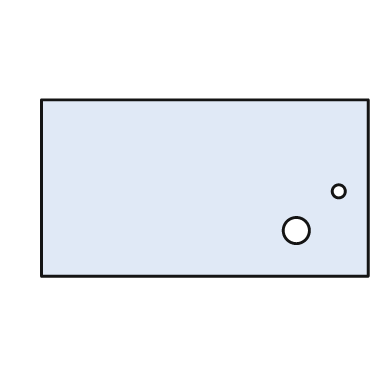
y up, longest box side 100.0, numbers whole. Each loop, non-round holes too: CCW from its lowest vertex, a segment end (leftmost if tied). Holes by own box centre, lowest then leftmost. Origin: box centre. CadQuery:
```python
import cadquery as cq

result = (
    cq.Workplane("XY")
    .moveTo(-50.0, -27.0)
    .lineTo(50.0, -27.0)
    .lineTo(50.0, 27.0)
    .lineTo(-50.0, 27.0)
    .close()
    .moveTo(28.0, -13.0)
    .circle(4.0)
    .moveTo(41.0, -1.0)
    .circle(2.0)
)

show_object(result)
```